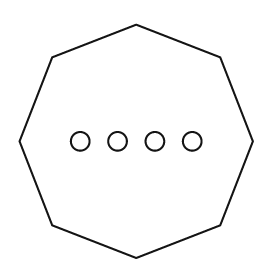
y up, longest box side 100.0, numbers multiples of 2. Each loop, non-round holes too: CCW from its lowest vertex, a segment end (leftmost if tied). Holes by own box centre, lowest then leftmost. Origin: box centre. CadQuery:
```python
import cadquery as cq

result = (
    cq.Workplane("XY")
    .moveTo(0.0, -50.0)
    .lineTo(36.0, -36.0)
    .lineTo(50.0, 0.0)
    .lineTo(36.0, 36.0)
    .lineTo(0.0, 50.0)
    .lineTo(-36.0, 36.0)
    .lineTo(-50.0, 0.0)
    .lineTo(-36.0, -36.0)
    .close()
    .moveTo(-24.0, 0.0)
    .circle(4.0)
    .moveTo(-8.0, 0.0)
    .circle(4.0)
    .moveTo(8.0, 0.0)
    .circle(4.0)
    .moveTo(24.0, 0.0)
    .circle(4.0)
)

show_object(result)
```